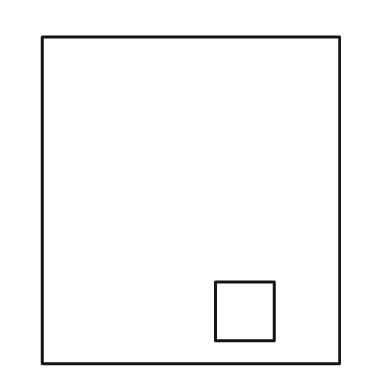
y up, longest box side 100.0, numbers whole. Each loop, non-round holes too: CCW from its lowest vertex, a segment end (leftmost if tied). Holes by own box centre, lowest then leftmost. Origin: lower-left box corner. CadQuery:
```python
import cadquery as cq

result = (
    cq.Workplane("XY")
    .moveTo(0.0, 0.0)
    .lineTo(91.0, 0.0)
    .lineTo(91.0, 100.0)
    .lineTo(0.0, 100.0)
    .close()
    .moveTo(53.0, 7.0)
    .lineTo(71.0, 7.0)
    .lineTo(71.0, 25.0)
    .lineTo(53.0, 25.0)
    .close()
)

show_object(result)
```